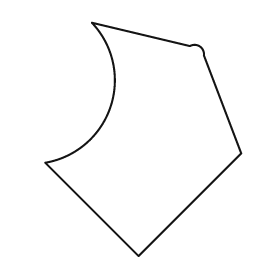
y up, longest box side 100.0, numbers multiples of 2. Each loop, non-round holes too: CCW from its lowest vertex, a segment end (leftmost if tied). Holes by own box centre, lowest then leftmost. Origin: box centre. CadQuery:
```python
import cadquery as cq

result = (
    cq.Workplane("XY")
    .moveTo(-2.0, -50.0)
    .lineTo(42.0, -6.0)
    .lineTo(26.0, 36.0)
    .threePointArc((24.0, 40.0), (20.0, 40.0))
    .lineTo(-22.0, 50.0)
    .threePointArc((-14.0, 14.0), (-42.0, -10.0))
    .close()
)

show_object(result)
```